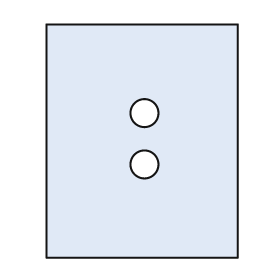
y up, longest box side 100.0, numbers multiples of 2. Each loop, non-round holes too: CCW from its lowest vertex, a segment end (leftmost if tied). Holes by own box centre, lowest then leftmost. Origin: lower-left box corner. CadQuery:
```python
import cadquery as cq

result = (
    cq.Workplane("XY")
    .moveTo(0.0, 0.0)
    .lineTo(82.0, 0.0)
    .lineTo(82.0, 100.0)
    .lineTo(0.0, 100.0)
    .close()
    .moveTo(42.0, 40.0)
    .circle(6.0)
    .moveTo(42.0, 62.0)
    .circle(6.0)
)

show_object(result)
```